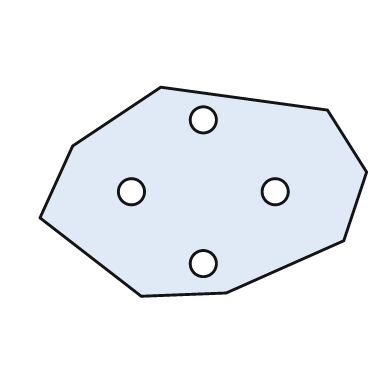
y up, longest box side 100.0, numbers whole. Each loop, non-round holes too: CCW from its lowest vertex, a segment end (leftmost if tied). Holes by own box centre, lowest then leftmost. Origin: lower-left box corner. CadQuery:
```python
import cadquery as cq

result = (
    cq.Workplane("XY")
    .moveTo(31.0, 0.0)
    .lineTo(57.0, 1.0)
    .lineTo(93.0, 17.0)
    .lineTo(100.0, 38.0)
    .lineTo(88.0, 57.0)
    .lineTo(37.0, 64.0)
    .lineTo(10.0, 46.0)
    .lineTo(0.0, 24.0)
    .close()
    .moveTo(50.0, 10.0)
    .circle(4.0)
    .moveTo(28.0, 32.0)
    .circle(4.0)
    .moveTo(72.0, 32.0)
    .circle(4.0)
    .moveTo(50.0, 54.0)
    .circle(4.0)
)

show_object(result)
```